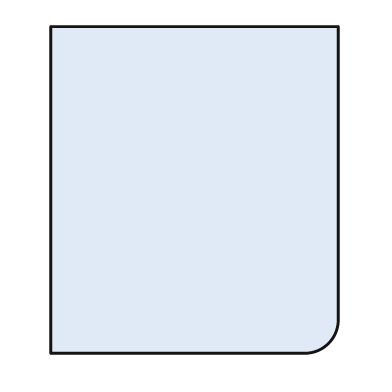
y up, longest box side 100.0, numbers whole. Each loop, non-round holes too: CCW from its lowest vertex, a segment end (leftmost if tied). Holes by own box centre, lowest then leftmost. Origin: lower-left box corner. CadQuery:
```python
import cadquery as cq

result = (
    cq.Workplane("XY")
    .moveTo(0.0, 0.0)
    .lineTo(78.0, 0.0)
    .threePointArc((85.0, 3.0), (88.0, 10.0))
    .lineTo(88.0, 100.0)
    .lineTo(0.0, 100.0)
    .close()
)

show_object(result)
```